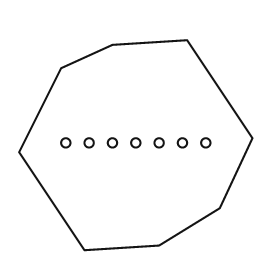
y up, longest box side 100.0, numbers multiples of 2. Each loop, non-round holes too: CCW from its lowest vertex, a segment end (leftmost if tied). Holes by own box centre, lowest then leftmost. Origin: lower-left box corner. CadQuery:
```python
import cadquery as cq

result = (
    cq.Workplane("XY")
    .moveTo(28.0, 0.0)
    .lineTo(60.0, 2.0)
    .lineTo(86.0, 18.0)
    .lineTo(100.0, 48.0)
    .lineTo(72.0, 90.0)
    .lineTo(40.0, 88.0)
    .lineTo(18.0, 78.0)
    .lineTo(0.0, 42.0)
    .close()
    .moveTo(20.0, 46.0)
    .circle(2.0)
    .moveTo(30.0, 46.0)
    .circle(2.0)
    .moveTo(40.0, 46.0)
    .circle(2.0)
    .moveTo(50.0, 46.0)
    .circle(2.0)
    .moveTo(60.0, 46.0)
    .circle(2.0)
    .moveTo(70.0, 46.0)
    .circle(2.0)
    .moveTo(80.0, 46.0)
    .circle(2.0)
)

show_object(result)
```